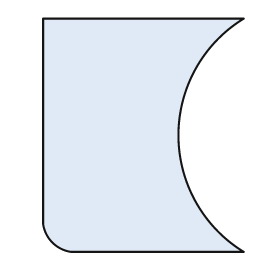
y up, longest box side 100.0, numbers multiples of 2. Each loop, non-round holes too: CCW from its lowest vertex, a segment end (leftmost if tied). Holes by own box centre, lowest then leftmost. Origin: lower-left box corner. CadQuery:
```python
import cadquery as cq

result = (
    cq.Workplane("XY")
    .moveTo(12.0, 0.0)
    .lineTo(86.0, 0.0)
    .threePointArc((58.0, 50.0), (86.0, 100.0))
    .lineTo(0.0, 100.0)
    .lineTo(0.0, 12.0)
    .threePointArc((4.0, 4.0), (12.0, 0.0))
    .close()
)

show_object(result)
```